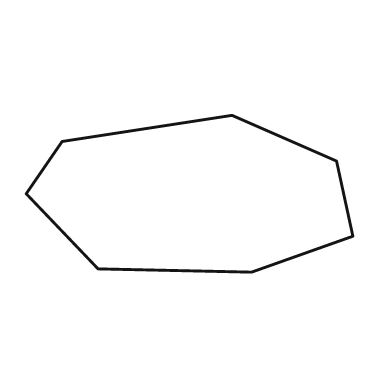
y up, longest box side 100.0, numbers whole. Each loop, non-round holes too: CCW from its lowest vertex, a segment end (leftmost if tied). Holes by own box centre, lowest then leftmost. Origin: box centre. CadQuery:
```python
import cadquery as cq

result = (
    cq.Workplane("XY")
    .moveTo(19.0, -24.0)
    .lineTo(50.0, -13.0)
    .lineTo(45.0, 10.0)
    .lineTo(13.0, 24.0)
    .lineTo(-39.0, 16.0)
    .lineTo(-50.0, 0.0)
    .lineTo(-28.0, -23.0)
    .close()
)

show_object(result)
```